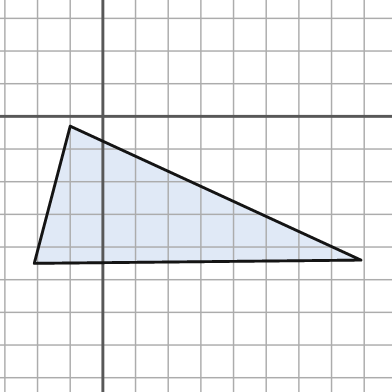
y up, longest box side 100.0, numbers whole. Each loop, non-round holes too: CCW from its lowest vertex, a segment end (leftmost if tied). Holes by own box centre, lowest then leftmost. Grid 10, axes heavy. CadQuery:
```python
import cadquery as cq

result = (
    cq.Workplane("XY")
    .moveTo(-21.0, -45.0)
    .lineTo(79.0, -44.0)
    .lineTo(-10.0, -3.0)
    .close()
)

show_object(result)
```